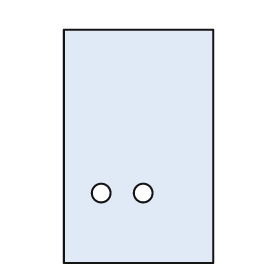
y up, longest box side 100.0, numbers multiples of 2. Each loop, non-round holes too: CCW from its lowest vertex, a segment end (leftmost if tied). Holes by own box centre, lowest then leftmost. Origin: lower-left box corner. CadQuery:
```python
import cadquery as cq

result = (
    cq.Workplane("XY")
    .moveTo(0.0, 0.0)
    .lineTo(64.0, 0.0)
    .lineTo(64.0, 100.0)
    .lineTo(0.0, 100.0)
    .close()
    .moveTo(16.0, 30.0)
    .circle(4.0)
    .moveTo(34.0, 30.0)
    .circle(4.0)
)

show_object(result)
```